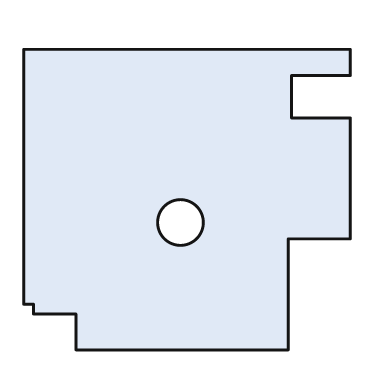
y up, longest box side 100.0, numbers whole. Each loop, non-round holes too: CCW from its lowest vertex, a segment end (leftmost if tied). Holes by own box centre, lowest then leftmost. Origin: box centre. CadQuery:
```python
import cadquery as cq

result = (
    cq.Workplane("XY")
    .moveTo(-34.0, -46.0)
    .lineTo(31.0, -46.0)
    .lineTo(31.0, -12.0)
    .lineTo(50.0, -12.0)
    .lineTo(50.0, 25.0)
    .lineTo(32.0, 25.0)
    .lineTo(32.0, 38.0)
    .lineTo(50.0, 38.0)
    .lineTo(50.0, 46.0)
    .lineTo(-50.0, 46.0)
    .lineTo(-50.0, -32.0)
    .lineTo(-47.0, -32.0)
    .lineTo(-47.0, -35.0)
    .lineTo(-34.0, -35.0)
    .close()
    .moveTo(-2.0, -7.0)
    .circle(7.0)
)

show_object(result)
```